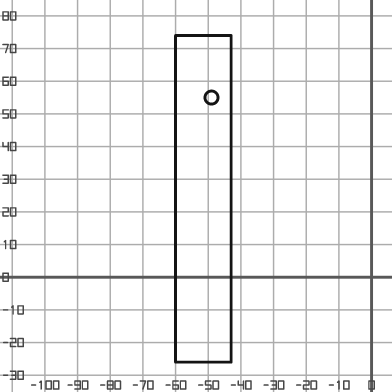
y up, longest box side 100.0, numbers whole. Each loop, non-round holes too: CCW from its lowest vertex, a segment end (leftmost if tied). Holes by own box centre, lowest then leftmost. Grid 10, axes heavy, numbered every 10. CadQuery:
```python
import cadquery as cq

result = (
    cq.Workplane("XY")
    .moveTo(-60.0, -26.0)
    .lineTo(-43.0, -26.0)
    .lineTo(-43.0, 74.0)
    .lineTo(-60.0, 74.0)
    .close()
    .moveTo(-49.0, 55.0)
    .circle(2.0)
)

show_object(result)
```